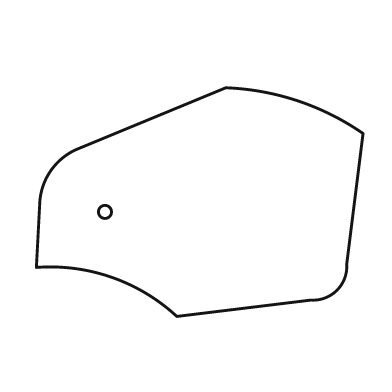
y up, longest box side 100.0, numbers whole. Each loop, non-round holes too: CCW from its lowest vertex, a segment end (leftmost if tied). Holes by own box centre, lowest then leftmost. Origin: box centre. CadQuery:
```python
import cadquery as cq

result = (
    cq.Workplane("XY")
    .moveTo(-7.0, -35.0)
    .lineTo(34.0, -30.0)
    .threePointArc((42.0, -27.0), (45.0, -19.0))
    .lineTo(50.0, 21.0)
    .threePointArc((30.0, 31.0), (8.0, 35.0))
    .lineTo(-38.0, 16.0)
    .threePointArc((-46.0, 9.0), (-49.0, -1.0))
    .lineTo(-50.0, -20.0)
    .threePointArc((-27.0, -23.0), (-7.0, -35.0))
    .close()
    .moveTo(-29.0, -3.0)
    .circle(2.0)
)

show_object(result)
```